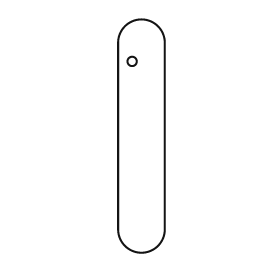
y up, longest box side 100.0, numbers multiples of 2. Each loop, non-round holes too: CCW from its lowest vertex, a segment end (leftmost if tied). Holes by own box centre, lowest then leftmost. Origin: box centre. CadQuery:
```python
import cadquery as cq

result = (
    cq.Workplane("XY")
    .moveTo(-10.0, -40.0)
    .threePointArc((0.0, -50.0), (10.0, -40.0))
    .lineTo(10.0, 40.0)
    .threePointArc((0.0, 50.0), (-10.0, 40.0))
    .close()
    .moveTo(-4.0, 32.0)
    .circle(2.0)
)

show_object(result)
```